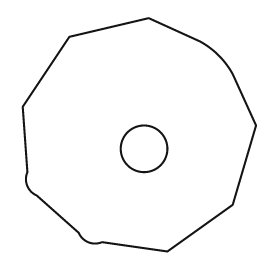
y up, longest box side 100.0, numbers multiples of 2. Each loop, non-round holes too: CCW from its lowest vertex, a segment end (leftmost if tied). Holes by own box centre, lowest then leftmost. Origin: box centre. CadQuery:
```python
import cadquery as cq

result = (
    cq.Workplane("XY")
    .moveTo(12.0, -50.0)
    .lineTo(40.0, -30.0)
    .lineTo(50.0, 4.0)
    .lineTo(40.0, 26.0)
    .threePointArc((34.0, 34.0), (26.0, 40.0))
    .lineTo(4.0, 50.0)
    .lineTo(-30.0, 42.0)
    .lineTo(-50.0, 12.0)
    .lineTo(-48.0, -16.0)
    .threePointArc((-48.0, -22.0), (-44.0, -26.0))
    .lineTo(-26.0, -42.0)
    .threePointArc((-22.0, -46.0), (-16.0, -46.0))
    .close()
    .moveTo(2.0, -6.0)
    .circle(10.0)
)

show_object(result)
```